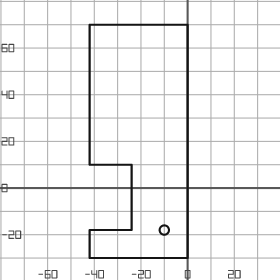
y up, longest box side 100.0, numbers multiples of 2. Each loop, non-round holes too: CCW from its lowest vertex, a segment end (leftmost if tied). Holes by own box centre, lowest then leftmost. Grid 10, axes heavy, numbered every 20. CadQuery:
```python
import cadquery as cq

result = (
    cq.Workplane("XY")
    .moveTo(-42.0, -30.0)
    .lineTo(0.0, -30.0)
    .lineTo(0.0, 70.0)
    .lineTo(-42.0, 70.0)
    .lineTo(-42.0, 10.0)
    .lineTo(-24.0, 10.0)
    .lineTo(-24.0, -18.0)
    .lineTo(-42.0, -18.0)
    .close()
    .moveTo(-10.0, -18.0)
    .circle(2.0)
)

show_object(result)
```